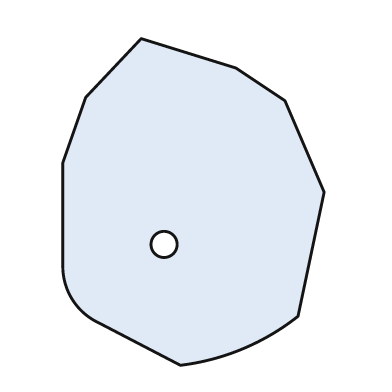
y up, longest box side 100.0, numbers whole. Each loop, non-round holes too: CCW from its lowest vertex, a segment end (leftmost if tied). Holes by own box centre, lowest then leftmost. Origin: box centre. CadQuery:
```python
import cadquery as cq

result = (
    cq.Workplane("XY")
    .moveTo(-4.0, -50.0)
    .threePointArc((15.0, -45.0), (32.0, -35.0))
    .lineTo(40.0, 3.0)
    .lineTo(28.0, 31.0)
    .lineTo(13.0, 41.0)
    .lineTo(-16.0, 50.0)
    .lineTo(-33.0, 32.0)
    .lineTo(-40.0, 12.0)
    .lineTo(-40.0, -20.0)
    .threePointArc((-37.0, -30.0), (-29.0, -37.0))
    .close()
    .moveTo(-9.0, -13.0)
    .circle(4.0)
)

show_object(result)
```